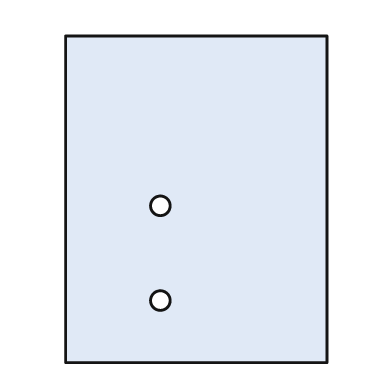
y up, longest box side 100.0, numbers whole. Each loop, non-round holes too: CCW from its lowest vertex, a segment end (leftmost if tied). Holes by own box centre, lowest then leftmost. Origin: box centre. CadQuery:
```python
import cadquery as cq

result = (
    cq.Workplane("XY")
    .moveTo(-40.0, -50.0)
    .lineTo(40.0, -50.0)
    .lineTo(40.0, 50.0)
    .lineTo(-40.0, 50.0)
    .close()
    .moveTo(-11.0, -31.0)
    .circle(3.0)
    .moveTo(-11.0, -2.0)
    .circle(3.0)
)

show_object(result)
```